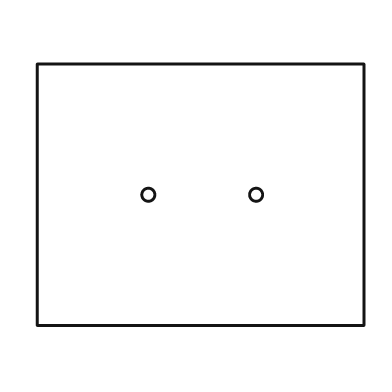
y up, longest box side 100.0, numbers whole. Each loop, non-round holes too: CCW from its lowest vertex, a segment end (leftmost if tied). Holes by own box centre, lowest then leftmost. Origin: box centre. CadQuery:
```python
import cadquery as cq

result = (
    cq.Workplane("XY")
    .moveTo(-50.0, -40.0)
    .lineTo(50.0, -40.0)
    .lineTo(50.0, 40.0)
    .lineTo(-50.0, 40.0)
    .close()
    .moveTo(-16.0, 0.0)
    .circle(2.0)
    .moveTo(17.0, 0.0)
    .circle(2.0)
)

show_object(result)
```